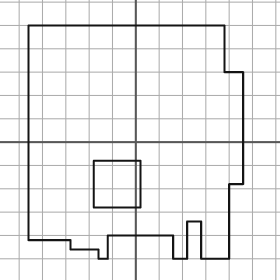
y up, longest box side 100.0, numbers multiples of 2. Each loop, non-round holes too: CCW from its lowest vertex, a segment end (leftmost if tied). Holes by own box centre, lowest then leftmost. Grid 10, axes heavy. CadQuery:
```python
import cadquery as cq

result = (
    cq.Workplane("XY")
    .moveTo(-16.0, -50.0)
    .lineTo(-12.0, -50.0)
    .lineTo(-12.0, -40.0)
    .lineTo(16.0, -40.0)
    .lineTo(16.0, -50.0)
    .lineTo(22.0, -50.0)
    .lineTo(22.0, -34.0)
    .lineTo(28.0, -34.0)
    .lineTo(28.0, -50.0)
    .lineTo(40.0, -50.0)
    .lineTo(40.0, -18.0)
    .lineTo(46.0, -18.0)
    .lineTo(46.0, 30.0)
    .lineTo(38.0, 30.0)
    .lineTo(38.0, 50.0)
    .lineTo(-46.0, 50.0)
    .lineTo(-46.0, -42.0)
    .lineTo(-28.0, -42.0)
    .lineTo(-28.0, -46.0)
    .lineTo(-16.0, -46.0)
    .close()
    .moveTo(-18.0, -28.0)
    .lineTo(2.0, -28.0)
    .lineTo(2.0, -8.0)
    .lineTo(-18.0, -8.0)
    .close()
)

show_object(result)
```